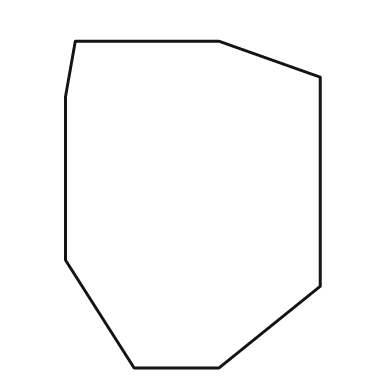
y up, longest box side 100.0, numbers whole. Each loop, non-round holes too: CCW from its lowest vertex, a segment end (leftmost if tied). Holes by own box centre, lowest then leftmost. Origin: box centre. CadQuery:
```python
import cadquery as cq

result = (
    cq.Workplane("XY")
    .moveTo(-18.0, -50.0)
    .lineTo(8.0, -50.0)
    .lineTo(39.0, -25.0)
    .lineTo(39.0, 39.0)
    .lineTo(8.0, 50.0)
    .lineTo(-36.0, 50.0)
    .lineTo(-39.0, 33.0)
    .lineTo(-39.0, -17.0)
    .close()
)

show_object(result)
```